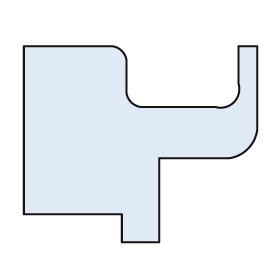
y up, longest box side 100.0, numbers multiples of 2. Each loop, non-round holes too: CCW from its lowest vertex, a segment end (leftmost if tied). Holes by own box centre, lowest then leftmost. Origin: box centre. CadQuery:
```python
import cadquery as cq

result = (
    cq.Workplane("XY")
    .moveTo(-8.0, -42.0)
    .lineTo(8.0, -42.0)
    .lineTo(8.0, -6.0)
    .lineTo(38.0, -6.0)
    .threePointArc((46.0, -2.0), (50.0, 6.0))
    .lineTo(50.0, 42.0)
    .lineTo(42.0, 42.0)
    .lineTo(42.0, 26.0)
    .threePointArc((40.0, 18.0), (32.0, 16.0))
    .lineTo(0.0, 16.0)
    .threePointArc((-4.0, 18.0), (-6.0, 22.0))
    .lineTo(-6.0, 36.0)
    .threePointArc((-8.0, 40.0), (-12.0, 42.0))
    .lineTo(-50.0, 42.0)
    .lineTo(-50.0, -30.0)
    .lineTo(-8.0, -30.0)
    .close()
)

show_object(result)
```